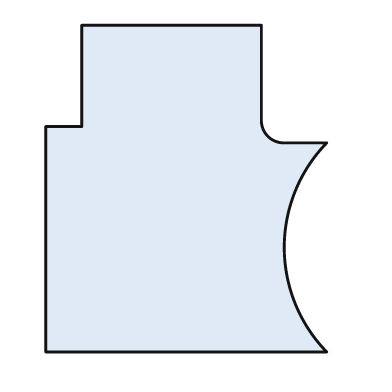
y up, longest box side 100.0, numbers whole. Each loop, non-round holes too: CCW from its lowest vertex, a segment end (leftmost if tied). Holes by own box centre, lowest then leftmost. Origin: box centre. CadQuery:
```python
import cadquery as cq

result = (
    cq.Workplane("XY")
    .moveTo(-43.0, -50.0)
    .lineTo(43.0, -50.0)
    .threePointArc((30.0, -18.0), (43.0, 14.0))
    .lineTo(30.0, 14.0)
    .threePointArc((25.0, 16.0), (23.0, 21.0))
    .lineTo(23.0, 50.0)
    .lineTo(-32.0, 50.0)
    .lineTo(-32.0, 19.0)
    .lineTo(-43.0, 19.0)
    .close()
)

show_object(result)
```